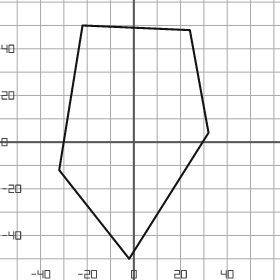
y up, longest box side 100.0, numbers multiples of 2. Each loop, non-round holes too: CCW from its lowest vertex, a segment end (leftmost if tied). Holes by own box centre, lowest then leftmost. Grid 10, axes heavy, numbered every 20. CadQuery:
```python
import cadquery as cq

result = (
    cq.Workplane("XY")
    .moveTo(-2.0, -50.0)
    .lineTo(32.0, 4.0)
    .lineTo(24.0, 48.0)
    .lineTo(-22.0, 50.0)
    .lineTo(-32.0, -12.0)
    .close()
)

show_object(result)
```